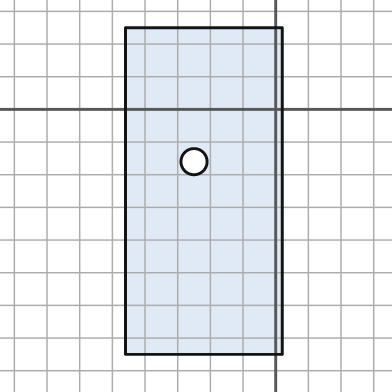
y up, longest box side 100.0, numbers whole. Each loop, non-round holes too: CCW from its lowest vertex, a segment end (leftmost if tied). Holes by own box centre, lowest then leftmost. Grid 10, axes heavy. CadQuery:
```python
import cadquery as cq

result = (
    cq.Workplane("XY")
    .moveTo(-46.0, -75.0)
    .lineTo(2.0, -75.0)
    .lineTo(2.0, 25.0)
    .lineTo(-46.0, 25.0)
    .close()
    .moveTo(-25.0, -16.0)
    .circle(4.0)
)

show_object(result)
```